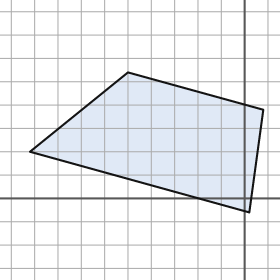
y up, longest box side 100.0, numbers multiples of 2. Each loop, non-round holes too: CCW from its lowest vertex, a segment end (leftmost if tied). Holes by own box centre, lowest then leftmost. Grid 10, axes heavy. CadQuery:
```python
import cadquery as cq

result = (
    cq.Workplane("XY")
    .moveTo(2.0, -6.0)
    .lineTo(8.0, 38.0)
    .lineTo(-50.0, 54.0)
    .lineTo(-92.0, 20.0)
    .close()
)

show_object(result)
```